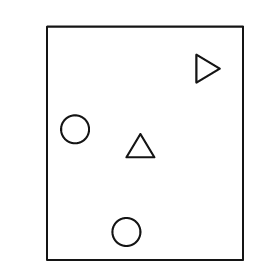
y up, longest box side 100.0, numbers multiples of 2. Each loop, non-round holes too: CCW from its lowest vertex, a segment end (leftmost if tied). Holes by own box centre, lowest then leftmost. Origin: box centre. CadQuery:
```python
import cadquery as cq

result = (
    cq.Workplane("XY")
    .moveTo(-42.0, -50.0)
    .lineTo(42.0, -50.0)
    .lineTo(42.0, 50.0)
    .lineTo(-42.0, 50.0)
    .close()
    .moveTo(-8.0, -38.0)
    .circle(6.0)
    .moveTo(-8.0, -6.0)
    .lineTo(4.0, -6.0)
    .lineTo(-2.0, 4.0)
    .close()
    .moveTo(-30.0, 6.0)
    .circle(6.0)
    .moveTo(22.0, 26.0)
    .lineTo(32.0, 32.0)
    .lineTo(22.0, 38.0)
    .close()
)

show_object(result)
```